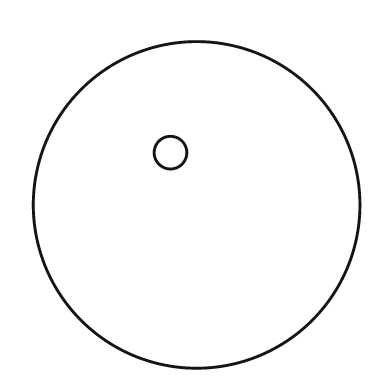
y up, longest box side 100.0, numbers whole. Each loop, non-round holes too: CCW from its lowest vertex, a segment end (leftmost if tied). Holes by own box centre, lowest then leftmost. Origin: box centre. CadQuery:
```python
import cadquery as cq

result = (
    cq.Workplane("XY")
    .moveTo(0.0, 0.0)
    .circle(50.0)
    .moveTo(-8.0, 16.0)
    .circle(5.0)
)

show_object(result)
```